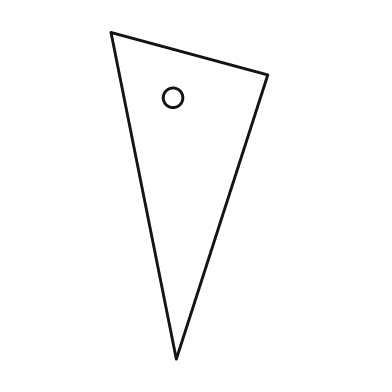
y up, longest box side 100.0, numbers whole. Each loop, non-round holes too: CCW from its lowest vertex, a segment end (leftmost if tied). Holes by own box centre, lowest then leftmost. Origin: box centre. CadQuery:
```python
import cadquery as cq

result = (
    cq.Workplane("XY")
    .moveTo(-4.0, -50.0)
    .lineTo(24.0, 37.0)
    .lineTo(-24.0, 50.0)
    .close()
    .moveTo(-5.0, 30.0)
    .circle(3.0)
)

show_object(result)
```